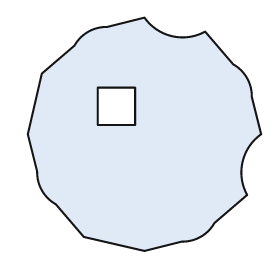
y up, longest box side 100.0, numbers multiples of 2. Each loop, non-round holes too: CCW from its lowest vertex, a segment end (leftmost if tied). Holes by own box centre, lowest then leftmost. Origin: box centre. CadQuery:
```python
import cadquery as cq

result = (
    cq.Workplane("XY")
    .moveTo(0.0, -50.0)
    .lineTo(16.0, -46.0)
    .threePointArc((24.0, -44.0), (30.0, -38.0))
    .lineTo(44.0, -26.0)
    .threePointArc((42.0, -12.0), (50.0, 0.0))
    .lineTo(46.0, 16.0)
    .threePointArc((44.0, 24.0), (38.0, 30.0))
    .lineTo(26.0, 44.0)
    .threePointArc((12.0, 42.0), (0.0, 50.0))
    .lineTo(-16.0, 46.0)
    .threePointArc((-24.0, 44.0), (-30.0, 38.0))
    .lineTo(-44.0, 26.0)
    .lineTo(-50.0, 0.0)
    .lineTo(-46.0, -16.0)
    .threePointArc((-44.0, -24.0), (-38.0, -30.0))
    .lineTo(-26.0, -44.0)
    .close()
    .moveTo(-20.0, 4.0)
    .lineTo(-4.0, 4.0)
    .lineTo(-4.0, 20.0)
    .lineTo(-20.0, 20.0)
    .close()
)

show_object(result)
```